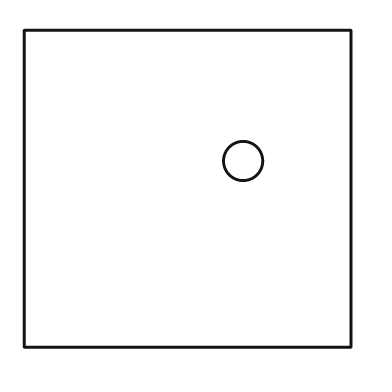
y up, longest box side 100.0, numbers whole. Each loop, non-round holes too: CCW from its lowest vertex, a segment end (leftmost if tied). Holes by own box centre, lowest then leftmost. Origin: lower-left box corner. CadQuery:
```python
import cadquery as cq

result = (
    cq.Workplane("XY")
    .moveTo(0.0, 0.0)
    .lineTo(100.0, 0.0)
    .lineTo(100.0, 97.0)
    .lineTo(0.0, 97.0)
    .close()
    .moveTo(67.0, 57.0)
    .circle(6.0)
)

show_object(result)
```